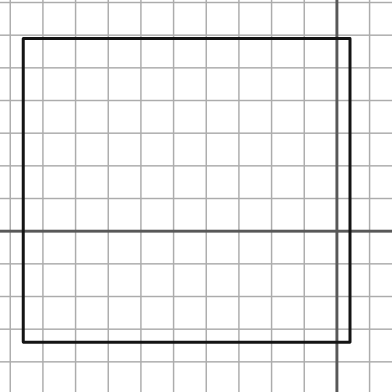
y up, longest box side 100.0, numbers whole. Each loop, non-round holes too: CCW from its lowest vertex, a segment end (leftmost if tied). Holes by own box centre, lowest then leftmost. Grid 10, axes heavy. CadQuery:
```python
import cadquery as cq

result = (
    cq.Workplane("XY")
    .moveTo(-96.0, -34.0)
    .lineTo(4.0, -34.0)
    .lineTo(4.0, 59.0)
    .lineTo(-96.0, 59.0)
    .close()
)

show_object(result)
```